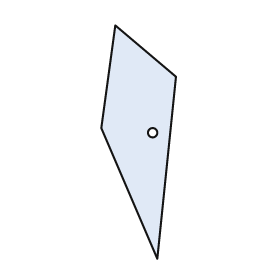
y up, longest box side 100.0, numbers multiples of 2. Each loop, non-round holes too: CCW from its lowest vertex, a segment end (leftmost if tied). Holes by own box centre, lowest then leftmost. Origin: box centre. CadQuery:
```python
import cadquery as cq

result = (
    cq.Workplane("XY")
    .moveTo(8.0, -50.0)
    .lineTo(16.0, 28.0)
    .lineTo(-10.0, 50.0)
    .lineTo(-16.0, 6.0)
    .close()
    .moveTo(6.0, 4.0)
    .circle(2.0)
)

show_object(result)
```